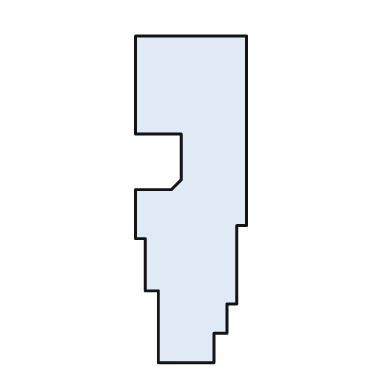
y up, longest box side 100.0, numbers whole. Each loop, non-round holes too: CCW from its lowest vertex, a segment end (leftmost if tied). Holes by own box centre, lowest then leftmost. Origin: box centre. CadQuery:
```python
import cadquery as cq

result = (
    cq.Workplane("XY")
    .moveTo(-10.0, -50.0)
    .lineTo(7.0, -50.0)
    .lineTo(7.0, -41.0)
    .lineTo(11.0, -41.0)
    .lineTo(11.0, -32.0)
    .lineTo(14.0, -32.0)
    .lineTo(14.0, -8.0)
    .lineTo(17.0, -8.0)
    .lineTo(17.0, 50.0)
    .lineTo(-17.0, 50.0)
    .lineTo(-17.0, 20.0)
    .lineTo(-3.0, 20.0)
    .lineTo(-3.0, 6.0)
    .lineTo(-6.0, 3.0)
    .lineTo(-17.0, 3.0)
    .lineTo(-17.0, -12.0)
    .lineTo(-14.0, -12.0)
    .lineTo(-14.0, -28.0)
    .lineTo(-10.0, -28.0)
    .close()
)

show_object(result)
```